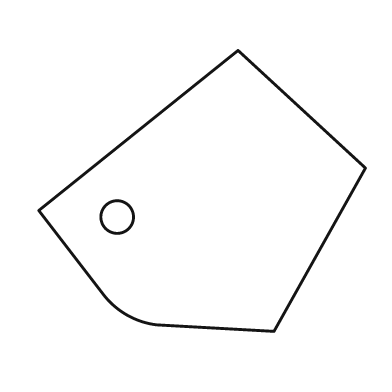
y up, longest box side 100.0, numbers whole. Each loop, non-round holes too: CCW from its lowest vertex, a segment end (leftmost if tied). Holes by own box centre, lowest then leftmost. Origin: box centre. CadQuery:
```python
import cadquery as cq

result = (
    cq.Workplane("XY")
    .moveTo(22.0, -43.0)
    .lineTo(50.0, 7.0)
    .lineTo(11.0, 43.0)
    .lineTo(-50.0, -6.0)
    .lineTo(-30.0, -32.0)
    .threePointArc((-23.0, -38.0), (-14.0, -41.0))
    .close()
    .moveTo(-26.0, -8.0)
    .circle(5.0)
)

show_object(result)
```